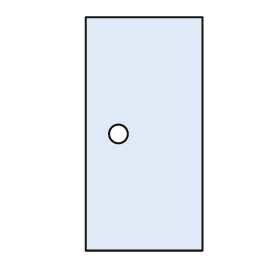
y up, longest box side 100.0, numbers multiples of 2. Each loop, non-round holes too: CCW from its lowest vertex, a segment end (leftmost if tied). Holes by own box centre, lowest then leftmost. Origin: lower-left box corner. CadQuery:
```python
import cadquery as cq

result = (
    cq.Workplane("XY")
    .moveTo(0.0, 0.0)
    .lineTo(50.0, 0.0)
    .lineTo(50.0, 100.0)
    .lineTo(0.0, 100.0)
    .close()
    .moveTo(14.0, 50.0)
    .circle(4.0)
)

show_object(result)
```